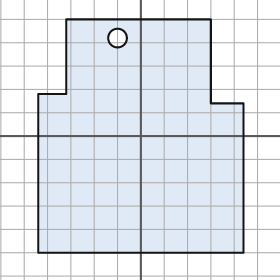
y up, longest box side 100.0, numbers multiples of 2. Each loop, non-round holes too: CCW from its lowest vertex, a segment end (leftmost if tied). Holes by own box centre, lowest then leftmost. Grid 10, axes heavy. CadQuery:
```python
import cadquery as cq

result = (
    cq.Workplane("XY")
    .moveTo(-44.0, -50.0)
    .lineTo(44.0, -50.0)
    .lineTo(44.0, 14.0)
    .lineTo(30.0, 14.0)
    .lineTo(30.0, 50.0)
    .lineTo(-32.0, 50.0)
    .lineTo(-32.0, 18.0)
    .lineTo(-44.0, 18.0)
    .close()
    .moveTo(-10.0, 42.0)
    .circle(4.0)
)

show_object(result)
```